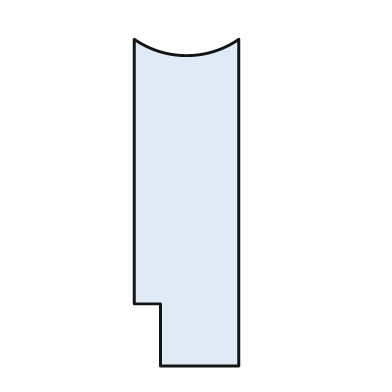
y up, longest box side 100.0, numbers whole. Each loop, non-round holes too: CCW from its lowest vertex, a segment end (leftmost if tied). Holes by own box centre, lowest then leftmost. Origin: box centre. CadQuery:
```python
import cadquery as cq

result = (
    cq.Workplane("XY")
    .moveTo(-8.0, -50.0)
    .lineTo(16.0, -50.0)
    .lineTo(16.0, 50.0)
    .threePointArc((0.0, 45.0), (-16.0, 50.0))
    .lineTo(-16.0, -31.0)
    .lineTo(-8.0, -31.0)
    .close()
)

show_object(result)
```